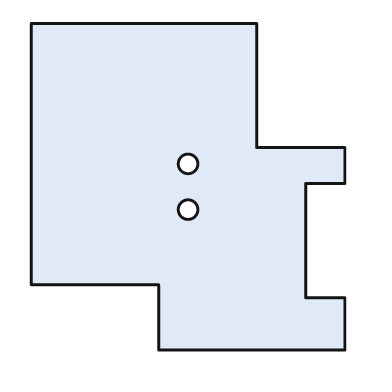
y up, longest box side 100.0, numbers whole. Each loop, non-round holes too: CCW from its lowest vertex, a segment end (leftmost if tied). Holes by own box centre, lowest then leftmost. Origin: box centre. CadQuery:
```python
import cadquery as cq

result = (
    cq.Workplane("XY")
    .moveTo(-9.0, -50.0)
    .lineTo(48.0, -50.0)
    .lineTo(48.0, -34.0)
    .lineTo(36.0, -34.0)
    .lineTo(36.0, 1.0)
    .lineTo(48.0, 1.0)
    .lineTo(48.0, 12.0)
    .lineTo(21.0, 12.0)
    .lineTo(21.0, 50.0)
    .lineTo(-48.0, 50.0)
    .lineTo(-48.0, -30.0)
    .lineTo(-9.0, -30.0)
    .close()
    .moveTo(0.0, -7.0)
    .circle(3.0)
    .moveTo(0.0, 7.0)
    .circle(3.0)
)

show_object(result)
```